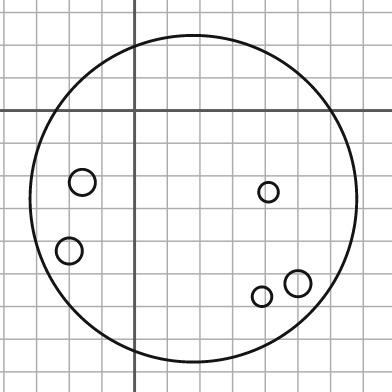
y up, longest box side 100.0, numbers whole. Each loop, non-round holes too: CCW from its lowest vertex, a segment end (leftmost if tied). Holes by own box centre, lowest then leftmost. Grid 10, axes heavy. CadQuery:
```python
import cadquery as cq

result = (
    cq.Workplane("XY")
    .moveTo(18.0, -27.0)
    .circle(50.0)
    .moveTo(39.0, -57.0)
    .circle(3.0)
    .moveTo(50.0, -53.0)
    .circle(4.0)
    .moveTo(-20.0, -43.0)
    .circle(4.0)
    .moveTo(41.0, -25.0)
    .circle(3.0)
    .moveTo(-16.0, -22.0)
    .circle(4.0)
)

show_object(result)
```